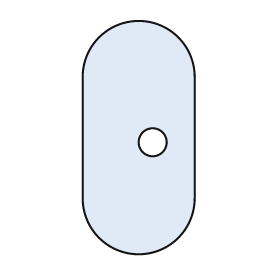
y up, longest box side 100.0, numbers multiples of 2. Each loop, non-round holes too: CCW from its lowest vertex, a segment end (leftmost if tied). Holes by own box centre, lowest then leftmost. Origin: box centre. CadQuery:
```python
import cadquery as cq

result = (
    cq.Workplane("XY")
    .moveTo(-24.0, -26.0)
    .threePointArc((0.0, -50.0), (24.0, -26.0))
    .lineTo(24.0, 26.0)
    .threePointArc((0.0, 50.0), (-24.0, 26.0))
    .close()
    .moveTo(6.0, -2.0)
    .circle(6.0)
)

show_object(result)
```